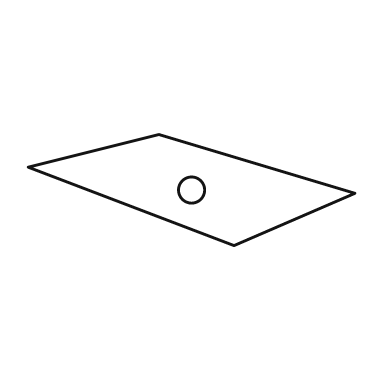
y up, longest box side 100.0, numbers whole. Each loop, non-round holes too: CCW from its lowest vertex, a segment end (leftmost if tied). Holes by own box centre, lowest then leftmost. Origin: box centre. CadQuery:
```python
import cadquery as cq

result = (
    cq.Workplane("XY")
    .moveTo(13.0, -17.0)
    .lineTo(50.0, -1.0)
    .lineTo(-10.0, 17.0)
    .lineTo(-50.0, 7.0)
    .close()
    .moveTo(0.0, 0.0)
    .circle(4.0)
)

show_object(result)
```